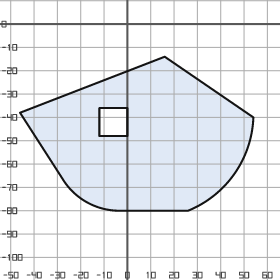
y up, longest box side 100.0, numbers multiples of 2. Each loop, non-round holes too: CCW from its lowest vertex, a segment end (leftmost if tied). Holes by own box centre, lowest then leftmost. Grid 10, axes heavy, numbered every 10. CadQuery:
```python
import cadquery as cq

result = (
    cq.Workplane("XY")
    .moveTo(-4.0, -80.0)
    .lineTo(26.0, -80.0)
    .threePointArc((46.0, -64.0), (54.0, -40.0))
    .lineTo(16.0, -14.0)
    .lineTo(-46.0, -38.0)
    .lineTo(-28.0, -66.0)
    .threePointArc((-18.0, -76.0), (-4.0, -80.0))
    .close()
    .moveTo(-12.0, -48.0)
    .lineTo(0.0, -48.0)
    .lineTo(0.0, -36.0)
    .lineTo(-12.0, -36.0)
    .close()
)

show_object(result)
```